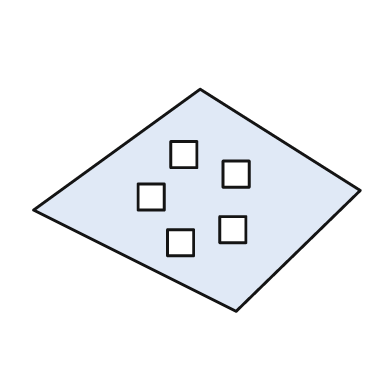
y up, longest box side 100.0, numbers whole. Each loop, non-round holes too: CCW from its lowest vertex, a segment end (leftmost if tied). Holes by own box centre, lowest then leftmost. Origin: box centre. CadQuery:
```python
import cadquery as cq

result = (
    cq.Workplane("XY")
    .moveTo(12.0, -34.0)
    .lineTo(50.0, 3.0)
    .lineTo(1.0, 34.0)
    .lineTo(-50.0, -3.0)
    .close()
    .moveTo(-9.0, -17.0)
    .lineTo(-1.0, -17.0)
    .lineTo(-1.0, -9.0)
    .lineTo(-9.0, -9.0)
    .close()
    .moveTo(7.0, -13.0)
    .lineTo(15.0, -13.0)
    .lineTo(15.0, -5.0)
    .lineTo(7.0, -5.0)
    .close()
    .moveTo(-18.0, -3.0)
    .lineTo(-10.0, -3.0)
    .lineTo(-10.0, 5.0)
    .lineTo(-18.0, 5.0)
    .close()
    .moveTo(8.0, 4.0)
    .lineTo(16.0, 4.0)
    .lineTo(16.0, 12.0)
    .lineTo(8.0, 12.0)
    .close()
    .moveTo(-8.0, 10.0)
    .lineTo(0.0, 10.0)
    .lineTo(0.0, 18.0)
    .lineTo(-8.0, 18.0)
    .close()
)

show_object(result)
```